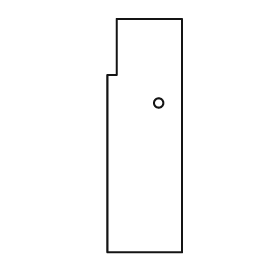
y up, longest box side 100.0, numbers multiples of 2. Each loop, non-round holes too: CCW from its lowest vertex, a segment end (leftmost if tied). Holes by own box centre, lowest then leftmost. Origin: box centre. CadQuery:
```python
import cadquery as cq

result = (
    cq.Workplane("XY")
    .moveTo(-16.0, -50.0)
    .lineTo(16.0, -50.0)
    .lineTo(16.0, 50.0)
    .lineTo(-12.0, 50.0)
    .lineTo(-12.0, 26.0)
    .lineTo(-16.0, 26.0)
    .close()
    .moveTo(6.0, 14.0)
    .circle(2.0)
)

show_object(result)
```